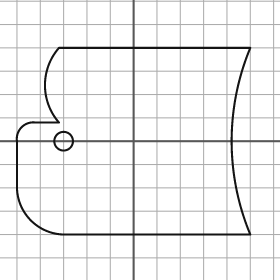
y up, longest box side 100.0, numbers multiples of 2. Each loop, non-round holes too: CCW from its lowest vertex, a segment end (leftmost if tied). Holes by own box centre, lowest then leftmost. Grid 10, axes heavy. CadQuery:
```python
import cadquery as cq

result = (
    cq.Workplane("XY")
    .moveTo(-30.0, -40.0)
    .lineTo(50.0, -40.0)
    .threePointArc((42.0, 0.0), (50.0, 40.0))
    .lineTo(-32.0, 40.0)
    .threePointArc((-38.0, 24.0), (-32.0, 8.0))
    .lineTo(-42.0, 8.0)
    .threePointArc((-48.0, 6.0), (-50.0, 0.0))
    .lineTo(-50.0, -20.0)
    .threePointArc((-44.0, -34.0), (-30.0, -40.0))
    .close()
    .moveTo(-30.0, 0.0)
    .circle(4.0)
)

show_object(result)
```